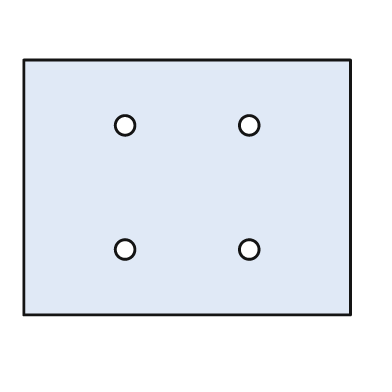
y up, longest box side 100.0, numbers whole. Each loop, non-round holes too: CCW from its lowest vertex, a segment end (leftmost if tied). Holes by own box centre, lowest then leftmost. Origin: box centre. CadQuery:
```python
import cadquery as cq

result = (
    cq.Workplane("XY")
    .moveTo(-50.0, -39.0)
    .lineTo(50.0, -39.0)
    .lineTo(50.0, 39.0)
    .lineTo(-50.0, 39.0)
    .close()
    .moveTo(-19.0, -19.0)
    .circle(3.0)
    .moveTo(19.0, -19.0)
    .circle(3.0)
    .moveTo(-19.0, 19.0)
    .circle(3.0)
    .moveTo(19.0, 19.0)
    .circle(3.0)
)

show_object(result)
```